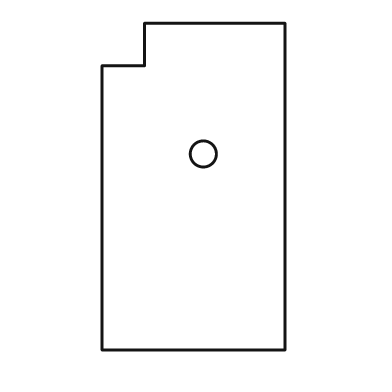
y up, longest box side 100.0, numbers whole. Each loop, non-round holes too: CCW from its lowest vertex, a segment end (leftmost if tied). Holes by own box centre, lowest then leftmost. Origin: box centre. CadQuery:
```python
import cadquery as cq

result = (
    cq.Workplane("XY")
    .moveTo(-28.0, -50.0)
    .lineTo(28.0, -50.0)
    .lineTo(28.0, 50.0)
    .lineTo(-15.0, 50.0)
    .lineTo(-15.0, 37.0)
    .lineTo(-28.0, 37.0)
    .close()
    .moveTo(3.0, 10.0)
    .circle(4.0)
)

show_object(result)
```